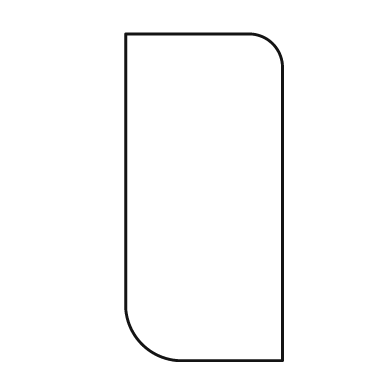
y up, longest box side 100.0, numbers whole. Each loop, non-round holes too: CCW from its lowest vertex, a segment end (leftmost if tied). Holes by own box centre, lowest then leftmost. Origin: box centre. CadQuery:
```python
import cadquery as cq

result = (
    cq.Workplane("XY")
    .moveTo(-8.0, -50.0)
    .lineTo(24.0, -50.0)
    .lineTo(24.0, 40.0)
    .threePointArc((21.0, 47.0), (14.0, 50.0))
    .lineTo(-24.0, 50.0)
    .lineTo(-24.0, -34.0)
    .threePointArc((-19.0, -45.0), (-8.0, -50.0))
    .close()
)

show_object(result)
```